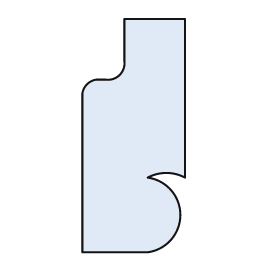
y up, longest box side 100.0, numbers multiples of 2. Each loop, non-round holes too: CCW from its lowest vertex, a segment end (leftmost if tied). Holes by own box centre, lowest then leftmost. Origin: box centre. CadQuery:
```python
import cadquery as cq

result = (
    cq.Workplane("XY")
    .moveTo(-22.0, -50.0)
    .lineTo(6.0, -50.0)
    .threePointArc((20.0, -34.0), (6.0, -18.0))
    .threePointArc((14.0, -16.0), (22.0, -18.0))
    .lineTo(22.0, 50.0)
    .lineTo(-4.0, 50.0)
    .lineTo(-4.0, 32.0)
    .threePointArc((-6.0, 26.0), (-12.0, 24.0))
    .lineTo(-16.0, 24.0)
    .threePointArc((-20.0, 22.0), (-22.0, 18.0))
    .close()
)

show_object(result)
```